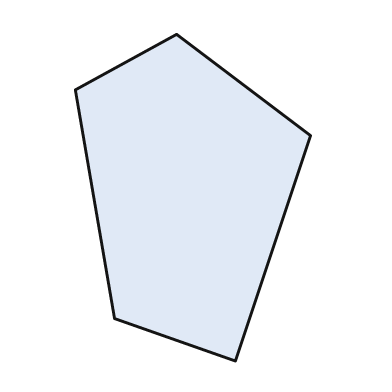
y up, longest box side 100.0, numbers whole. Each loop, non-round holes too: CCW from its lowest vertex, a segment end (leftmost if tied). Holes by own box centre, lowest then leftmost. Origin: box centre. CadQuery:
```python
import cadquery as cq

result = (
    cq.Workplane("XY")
    .moveTo(13.0, -50.0)
    .lineTo(36.0, 19.0)
    .lineTo(-5.0, 50.0)
    .lineTo(-36.0, 33.0)
    .lineTo(-24.0, -37.0)
    .close()
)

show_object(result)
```